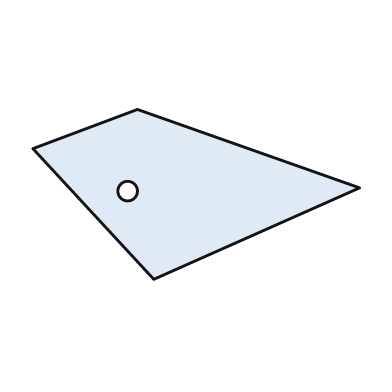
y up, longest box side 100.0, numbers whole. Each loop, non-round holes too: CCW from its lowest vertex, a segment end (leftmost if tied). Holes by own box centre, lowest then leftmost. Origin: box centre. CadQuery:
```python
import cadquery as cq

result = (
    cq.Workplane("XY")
    .moveTo(-13.0, -26.0)
    .lineTo(50.0, 2.0)
    .lineTo(-18.0, 26.0)
    .lineTo(-50.0, 14.0)
    .close()
    .moveTo(-21.0, 1.0)
    .circle(3.0)
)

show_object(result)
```